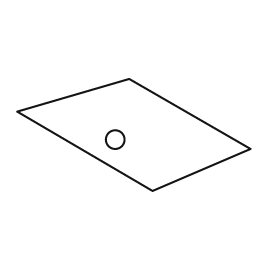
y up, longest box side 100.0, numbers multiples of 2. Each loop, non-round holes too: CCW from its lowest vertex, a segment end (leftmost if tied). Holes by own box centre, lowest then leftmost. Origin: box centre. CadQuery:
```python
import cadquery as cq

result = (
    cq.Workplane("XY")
    .moveTo(8.0, -24.0)
    .lineTo(50.0, -6.0)
    .lineTo(-2.0, 24.0)
    .lineTo(-50.0, 10.0)
    .close()
    .moveTo(-8.0, -2.0)
    .circle(4.0)
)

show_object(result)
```